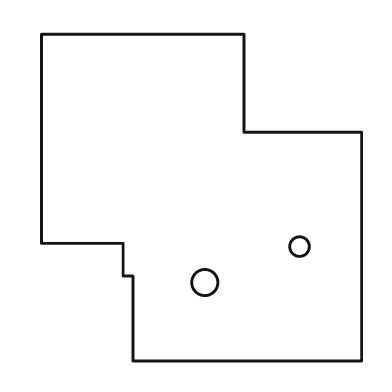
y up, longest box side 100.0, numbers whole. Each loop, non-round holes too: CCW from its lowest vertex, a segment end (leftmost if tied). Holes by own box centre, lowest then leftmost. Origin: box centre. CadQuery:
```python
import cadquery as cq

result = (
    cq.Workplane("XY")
    .moveTo(-21.0, -50.0)
    .lineTo(49.0, -50.0)
    .lineTo(49.0, 20.0)
    .lineTo(13.0, 20.0)
    .lineTo(13.0, 50.0)
    .lineTo(-49.0, 50.0)
    .lineTo(-49.0, -14.0)
    .lineTo(-24.0, -14.0)
    .lineTo(-24.0, -24.0)
    .lineTo(-21.0, -24.0)
    .close()
    .moveTo(1.0, -26.0)
    .circle(4.0)
    .moveTo(30.0, -15.0)
    .circle(3.0)
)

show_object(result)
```